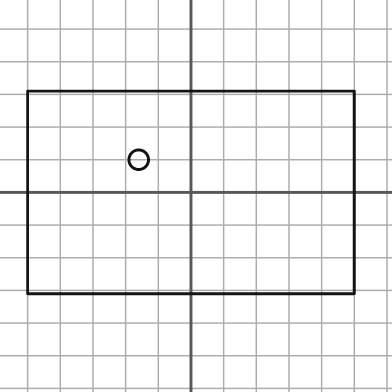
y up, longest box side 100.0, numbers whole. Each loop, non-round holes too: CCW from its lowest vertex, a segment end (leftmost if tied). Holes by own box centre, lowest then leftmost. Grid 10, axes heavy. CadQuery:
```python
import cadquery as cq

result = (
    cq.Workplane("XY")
    .moveTo(-50.0, -31.0)
    .lineTo(50.0, -31.0)
    .lineTo(50.0, 31.0)
    .lineTo(-50.0, 31.0)
    .close()
    .moveTo(-16.0, 10.0)
    .circle(3.0)
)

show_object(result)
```